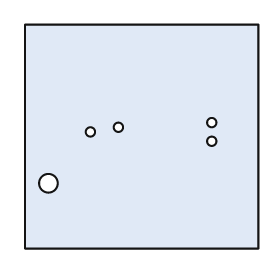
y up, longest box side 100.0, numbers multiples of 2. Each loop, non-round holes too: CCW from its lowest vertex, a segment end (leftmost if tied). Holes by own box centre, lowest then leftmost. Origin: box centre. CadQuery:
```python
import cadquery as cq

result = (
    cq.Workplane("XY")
    .moveTo(-50.0, -48.0)
    .lineTo(50.0, -48.0)
    .lineTo(50.0, 48.0)
    .lineTo(-50.0, 48.0)
    .close()
    .moveTo(-40.0, -20.0)
    .circle(4.0)
    .moveTo(30.0, -2.0)
    .circle(2.0)
    .moveTo(-22.0, 2.0)
    .circle(2.0)
    .moveTo(-10.0, 4.0)
    .circle(2.0)
    .moveTo(30.0, 6.0)
    .circle(2.0)
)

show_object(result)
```